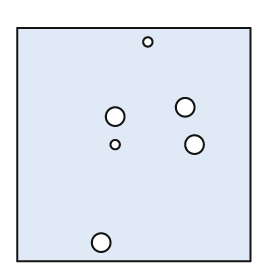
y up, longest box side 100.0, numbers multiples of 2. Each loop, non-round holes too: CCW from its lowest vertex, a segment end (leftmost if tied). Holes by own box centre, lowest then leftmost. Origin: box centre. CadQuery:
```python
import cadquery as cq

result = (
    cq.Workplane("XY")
    .moveTo(-50.0, -50.0)
    .lineTo(50.0, -50.0)
    .lineTo(50.0, 50.0)
    .lineTo(-50.0, 50.0)
    .close()
    .moveTo(-14.0, -42.0)
    .circle(4.0)
    .moveTo(-8.0, 0.0)
    .circle(2.0)
    .moveTo(26.0, 0.0)
    .circle(4.0)
    .moveTo(-8.0, 12.0)
    .circle(4.0)
    .moveTo(22.0, 16.0)
    .circle(4.0)
    .moveTo(6.0, 44.0)
    .circle(2.0)
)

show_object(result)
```